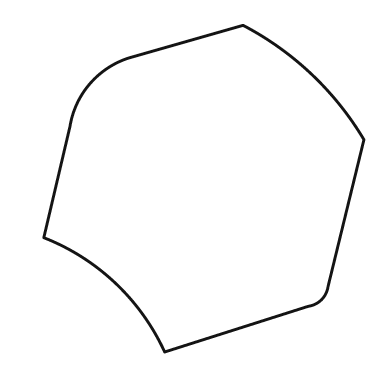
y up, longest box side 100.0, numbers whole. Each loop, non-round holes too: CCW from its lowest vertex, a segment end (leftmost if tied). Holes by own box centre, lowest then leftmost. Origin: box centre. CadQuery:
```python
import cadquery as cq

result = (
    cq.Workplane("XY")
    .moveTo(-12.0, -50.0)
    .lineTo(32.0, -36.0)
    .threePointArc((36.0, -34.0), (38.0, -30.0))
    .lineTo(49.0, 15.0)
    .threePointArc((33.0, 35.0), (12.0, 50.0))
    .lineTo(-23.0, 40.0)
    .threePointArc((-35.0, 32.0), (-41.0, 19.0))
    .lineTo(-49.0, -15.0)
    .threePointArc((-27.0, -29.0), (-12.0, -50.0))
    .close()
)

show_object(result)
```